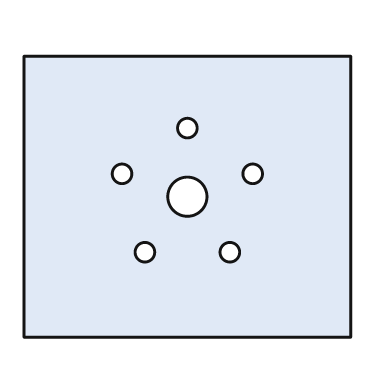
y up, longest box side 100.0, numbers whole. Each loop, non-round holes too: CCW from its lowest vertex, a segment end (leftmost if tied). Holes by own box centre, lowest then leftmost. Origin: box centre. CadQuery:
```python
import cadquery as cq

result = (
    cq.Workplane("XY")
    .moveTo(-50.0, -43.0)
    .lineTo(50.0, -43.0)
    .lineTo(50.0, 43.0)
    .lineTo(-50.0, 43.0)
    .close()
    .moveTo(-13.0, -17.0)
    .circle(3.0)
    .moveTo(13.0, -17.0)
    .circle(3.0)
    .moveTo(0.0, 0.0)
    .circle(6.0)
    .moveTo(-20.0, 7.0)
    .circle(3.0)
    .moveTo(20.0, 7.0)
    .circle(3.0)
    .moveTo(0.0, 21.0)
    .circle(3.0)
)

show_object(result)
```